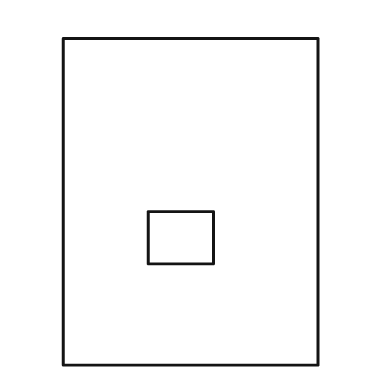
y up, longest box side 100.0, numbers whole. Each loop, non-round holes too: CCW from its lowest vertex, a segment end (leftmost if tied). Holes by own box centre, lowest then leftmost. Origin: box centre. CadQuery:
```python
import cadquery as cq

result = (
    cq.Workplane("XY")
    .moveTo(-39.0, -50.0)
    .lineTo(39.0, -50.0)
    .lineTo(39.0, 50.0)
    .lineTo(-39.0, 50.0)
    .close()
    .moveTo(-13.0, -19.0)
    .lineTo(7.0, -19.0)
    .lineTo(7.0, -3.0)
    .lineTo(-13.0, -3.0)
    .close()
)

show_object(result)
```